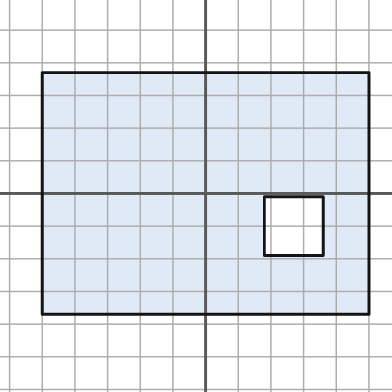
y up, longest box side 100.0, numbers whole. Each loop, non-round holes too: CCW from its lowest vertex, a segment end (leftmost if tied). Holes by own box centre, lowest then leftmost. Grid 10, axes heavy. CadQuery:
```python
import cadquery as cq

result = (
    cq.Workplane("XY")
    .moveTo(-50.0, -37.0)
    .lineTo(50.0, -37.0)
    .lineTo(50.0, 37.0)
    .lineTo(-50.0, 37.0)
    .close()
    .moveTo(18.0, -19.0)
    .lineTo(36.0, -19.0)
    .lineTo(36.0, -1.0)
    .lineTo(18.0, -1.0)
    .close()
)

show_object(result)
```